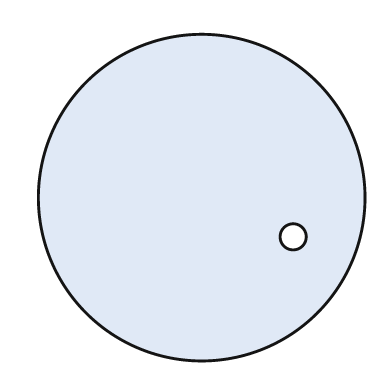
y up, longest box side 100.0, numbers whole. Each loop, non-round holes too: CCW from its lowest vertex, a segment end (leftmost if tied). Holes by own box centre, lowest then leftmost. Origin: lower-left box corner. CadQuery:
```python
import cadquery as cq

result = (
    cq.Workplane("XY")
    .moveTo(50.0, 50.0)
    .circle(50.0)
    .moveTo(78.0, 38.0)
    .circle(4.0)
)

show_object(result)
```